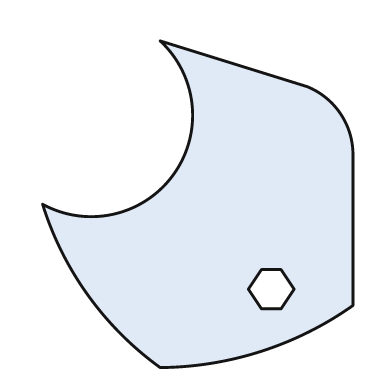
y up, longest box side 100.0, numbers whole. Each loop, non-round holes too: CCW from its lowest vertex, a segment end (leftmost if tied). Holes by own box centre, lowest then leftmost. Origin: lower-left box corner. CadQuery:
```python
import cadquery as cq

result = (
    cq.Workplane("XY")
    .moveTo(36.0, 0.0)
    .threePointArc((67.0, 5.0), (95.0, 19.0))
    .lineTo(95.0, 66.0)
    .threePointArc((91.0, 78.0), (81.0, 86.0))
    .lineTo(36.0, 100.0)
    .threePointArc((40.0, 59.0), (0.0, 50.0))
    .threePointArc((14.0, 22.0), (36.0, 0.0))
    .close()
    .moveTo(67.0, 18.0)
    .lineTo(73.0, 18.0)
    .lineTo(77.0, 24.0)
    .lineTo(73.0, 30.0)
    .lineTo(67.0, 30.0)
    .lineTo(63.0, 24.0)
    .close()
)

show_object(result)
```